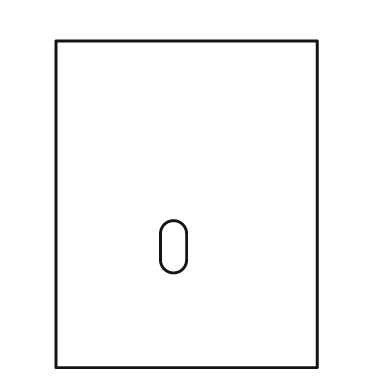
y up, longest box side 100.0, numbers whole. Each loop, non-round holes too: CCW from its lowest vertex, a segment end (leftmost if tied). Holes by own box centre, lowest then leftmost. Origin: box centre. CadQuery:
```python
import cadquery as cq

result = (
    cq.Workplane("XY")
    .moveTo(-40.0, -50.0)
    .lineTo(40.0, -50.0)
    .lineTo(40.0, 50.0)
    .lineTo(-40.0, 50.0)
    .close()
    .moveTo(-8.0, -17.0)
    .threePointArc((-4.0, -21.0), (0.0, -17.0))
    .lineTo(0.0, -9.0)
    .threePointArc((-4.0, -5.0), (-8.0, -9.0))
    .close()
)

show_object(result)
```